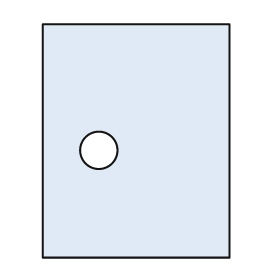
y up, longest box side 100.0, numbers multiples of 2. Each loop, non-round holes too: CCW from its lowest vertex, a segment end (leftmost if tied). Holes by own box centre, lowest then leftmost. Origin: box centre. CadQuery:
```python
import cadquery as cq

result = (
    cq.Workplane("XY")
    .moveTo(-40.0, -50.0)
    .lineTo(40.0, -50.0)
    .lineTo(40.0, 50.0)
    .lineTo(-40.0, 50.0)
    .close()
    .moveTo(-16.0, -4.0)
    .circle(8.0)
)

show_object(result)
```